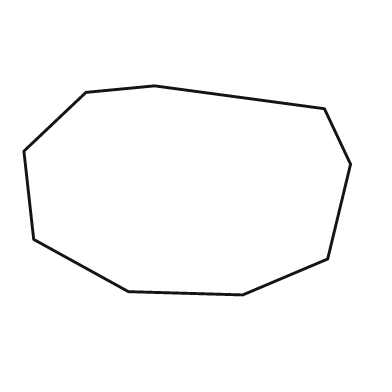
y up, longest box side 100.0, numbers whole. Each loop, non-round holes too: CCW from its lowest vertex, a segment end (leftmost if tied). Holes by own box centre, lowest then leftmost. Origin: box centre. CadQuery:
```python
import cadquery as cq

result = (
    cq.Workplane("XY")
    .moveTo(17.0, -32.0)
    .lineTo(43.0, -21.0)
    .lineTo(50.0, 8.0)
    .lineTo(42.0, 25.0)
    .lineTo(-10.0, 32.0)
    .lineTo(-31.0, 30.0)
    .lineTo(-50.0, 12.0)
    .lineTo(-47.0, -15.0)
    .lineTo(-18.0, -31.0)
    .close()
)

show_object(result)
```